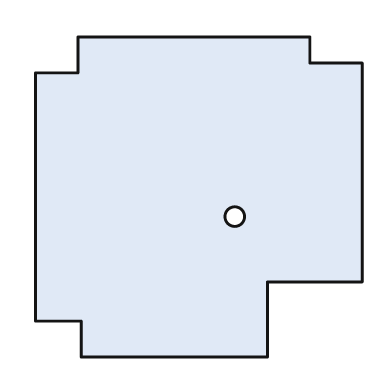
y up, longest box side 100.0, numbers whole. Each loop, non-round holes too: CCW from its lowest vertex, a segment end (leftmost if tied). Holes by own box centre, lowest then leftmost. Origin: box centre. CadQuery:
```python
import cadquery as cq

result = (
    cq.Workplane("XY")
    .moveTo(-36.0, -49.0)
    .lineTo(21.0, -49.0)
    .lineTo(21.0, -26.0)
    .lineTo(50.0, -26.0)
    .lineTo(50.0, 41.0)
    .lineTo(34.0, 41.0)
    .lineTo(34.0, 49.0)
    .lineTo(-37.0, 49.0)
    .lineTo(-37.0, 38.0)
    .lineTo(-50.0, 38.0)
    .lineTo(-50.0, -38.0)
    .lineTo(-36.0, -38.0)
    .close()
    .moveTo(11.0, -6.0)
    .circle(3.0)
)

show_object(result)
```